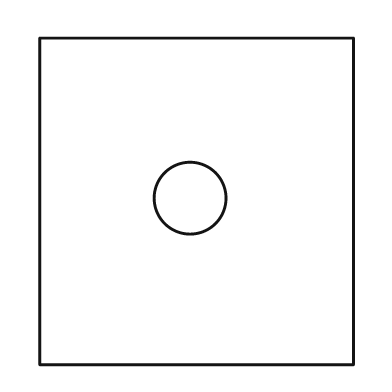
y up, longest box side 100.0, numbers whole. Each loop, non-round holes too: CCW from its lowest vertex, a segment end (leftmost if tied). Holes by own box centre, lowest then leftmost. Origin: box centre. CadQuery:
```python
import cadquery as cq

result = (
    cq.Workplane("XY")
    .moveTo(-48.0, -50.0)
    .lineTo(48.0, -50.0)
    .lineTo(48.0, 50.0)
    .lineTo(-48.0, 50.0)
    .close()
    .moveTo(-2.0, 1.0)
    .circle(11.0)
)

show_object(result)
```